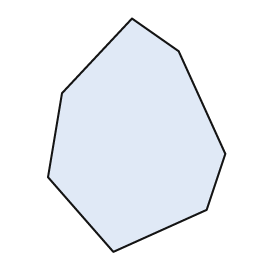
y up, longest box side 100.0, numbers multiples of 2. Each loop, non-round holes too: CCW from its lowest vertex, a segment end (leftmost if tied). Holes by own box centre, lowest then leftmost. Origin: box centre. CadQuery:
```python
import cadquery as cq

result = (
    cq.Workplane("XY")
    .moveTo(-10.0, -50.0)
    .lineTo(30.0, -32.0)
    .lineTo(38.0, -8.0)
    .lineTo(18.0, 36.0)
    .lineTo(-2.0, 50.0)
    .lineTo(-32.0, 18.0)
    .lineTo(-38.0, -18.0)
    .close()
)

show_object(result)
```